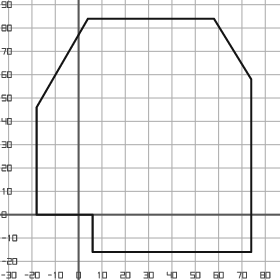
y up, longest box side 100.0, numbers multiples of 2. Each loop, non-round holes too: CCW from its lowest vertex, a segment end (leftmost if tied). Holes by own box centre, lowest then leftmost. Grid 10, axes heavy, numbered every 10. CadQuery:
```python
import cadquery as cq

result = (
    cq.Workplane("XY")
    .moveTo(6.0, -16.0)
    .lineTo(74.0, -16.0)
    .lineTo(74.0, 58.0)
    .lineTo(58.0, 84.0)
    .lineTo(4.0, 84.0)
    .lineTo(-18.0, 46.0)
    .lineTo(-18.0, 0.0)
    .lineTo(6.0, 0.0)
    .close()
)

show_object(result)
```